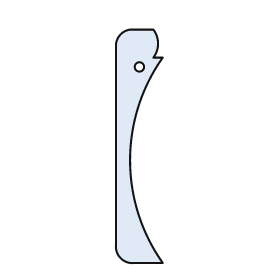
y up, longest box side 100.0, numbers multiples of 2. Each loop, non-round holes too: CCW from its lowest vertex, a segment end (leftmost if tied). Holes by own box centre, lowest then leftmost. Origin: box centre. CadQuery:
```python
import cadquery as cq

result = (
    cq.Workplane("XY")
    .moveTo(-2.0, -50.0)
    .lineTo(10.0, -50.0)
    .threePointArc((-4.0, -6.0), (10.0, 38.0))
    .lineTo(6.0, 38.0)
    .threePointArc((8.0, 44.0), (6.0, 50.0))
    .lineTo(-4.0, 50.0)
    .threePointArc((-8.0, 48.0), (-10.0, 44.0))
    .lineTo(-10.0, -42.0)
    .threePointArc((-8.0, -48.0), (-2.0, -50.0))
    .close()
    .moveTo(0.0, 34.0)
    .circle(2.0)
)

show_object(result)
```